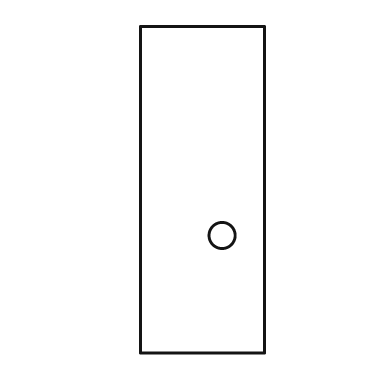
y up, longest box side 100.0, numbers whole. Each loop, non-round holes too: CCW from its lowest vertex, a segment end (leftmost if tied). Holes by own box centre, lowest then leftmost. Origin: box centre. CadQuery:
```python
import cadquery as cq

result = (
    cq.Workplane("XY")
    .moveTo(-19.0, -50.0)
    .lineTo(19.0, -50.0)
    .lineTo(19.0, 50.0)
    .lineTo(-19.0, 50.0)
    .close()
    .moveTo(6.0, -14.0)
    .circle(4.0)
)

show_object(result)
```